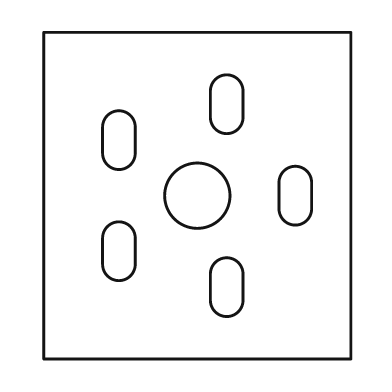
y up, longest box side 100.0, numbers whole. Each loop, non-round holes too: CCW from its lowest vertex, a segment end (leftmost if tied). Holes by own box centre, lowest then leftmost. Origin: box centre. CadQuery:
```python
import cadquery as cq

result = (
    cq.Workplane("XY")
    .moveTo(-47.0, -50.0)
    .lineTo(47.0, -50.0)
    .lineTo(47.0, 50.0)
    .lineTo(-47.0, 50.0)
    .close()
    .moveTo(4.0, -32.0)
    .threePointArc((9.0, -37.0), (14.0, -32.0))
    .lineTo(14.0, -24.0)
    .threePointArc((9.0, -19.0), (4.0, -24.0))
    .close()
    .moveTo(-29.0, -21.0)
    .threePointArc((-24.0, -26.0), (-19.0, -21.0))
    .lineTo(-19.0, -13.0)
    .threePointArc((-24.0, -8.0), (-29.0, -13.0))
    .close()
    .moveTo(0.0, 0.0)
    .circle(10.0)
    .moveTo(25.0, -4.0)
    .threePointArc((30.0, -9.0), (35.0, -4.0))
    .lineTo(35.0, 4.0)
    .threePointArc((30.0, 9.0), (25.0, 4.0))
    .close()
    .moveTo(-29.0, 13.0)
    .threePointArc((-24.0, 8.0), (-19.0, 13.0))
    .lineTo(-19.0, 21.0)
    .threePointArc((-24.0, 26.0), (-29.0, 21.0))
    .close()
    .moveTo(4.0, 24.0)
    .threePointArc((9.0, 19.0), (14.0, 24.0))
    .lineTo(14.0, 32.0)
    .threePointArc((9.0, 37.0), (4.0, 32.0))
    .close()
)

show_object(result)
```